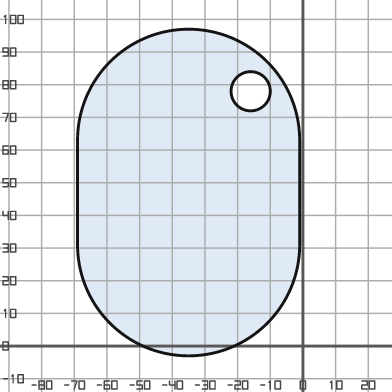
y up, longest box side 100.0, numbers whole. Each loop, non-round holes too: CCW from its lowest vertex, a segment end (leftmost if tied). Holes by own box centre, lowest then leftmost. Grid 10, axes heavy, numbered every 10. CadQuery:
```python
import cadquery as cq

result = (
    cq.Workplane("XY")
    .moveTo(-69.0, 31.0)
    .threePointArc((-35.0, -3.0), (-1.0, 31.0))
    .lineTo(-1.0, 63.0)
    .threePointArc((-35.0, 97.0), (-69.0, 63.0))
    .close()
    .moveTo(-16.0, 78.0)
    .circle(6.0)
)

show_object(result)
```